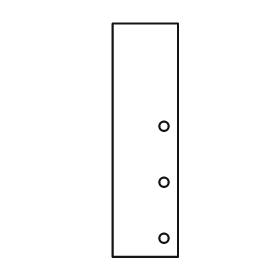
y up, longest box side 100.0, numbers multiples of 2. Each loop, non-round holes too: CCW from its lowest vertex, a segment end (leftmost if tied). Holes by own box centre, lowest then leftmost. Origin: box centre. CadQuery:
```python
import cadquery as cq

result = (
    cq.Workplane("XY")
    .moveTo(-14.0, -50.0)
    .lineTo(14.0, -50.0)
    .lineTo(14.0, 50.0)
    .lineTo(-14.0, 50.0)
    .close()
    .moveTo(8.0, -42.0)
    .circle(2.0)
    .moveTo(8.0, -18.0)
    .circle(2.0)
    .moveTo(8.0, 6.0)
    .circle(2.0)
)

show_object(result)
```